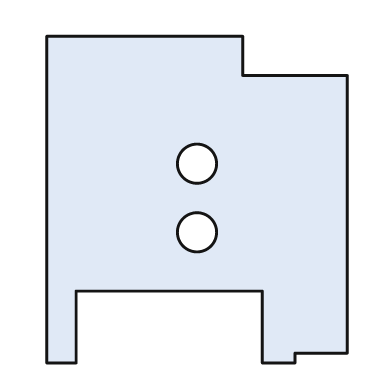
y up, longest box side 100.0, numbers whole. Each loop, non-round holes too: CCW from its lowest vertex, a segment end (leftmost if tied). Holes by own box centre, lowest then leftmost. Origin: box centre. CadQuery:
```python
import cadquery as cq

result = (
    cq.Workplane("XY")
    .moveTo(-46.0, -50.0)
    .lineTo(-37.0, -50.0)
    .lineTo(-37.0, -28.0)
    .lineTo(20.0, -28.0)
    .lineTo(20.0, -50.0)
    .lineTo(30.0, -50.0)
    .lineTo(30.0, -47.0)
    .lineTo(46.0, -47.0)
    .lineTo(46.0, 38.0)
    .lineTo(14.0, 38.0)
    .lineTo(14.0, 50.0)
    .lineTo(-46.0, 50.0)
    .close()
    .moveTo(0.0, -10.0)
    .circle(6.0)
    .moveTo(0.0, 11.0)
    .circle(6.0)
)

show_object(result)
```